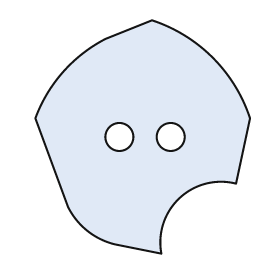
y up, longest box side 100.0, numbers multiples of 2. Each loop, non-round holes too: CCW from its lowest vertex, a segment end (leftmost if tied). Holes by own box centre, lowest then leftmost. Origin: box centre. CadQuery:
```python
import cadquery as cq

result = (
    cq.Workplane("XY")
    .moveTo(8.0, -50.0)
    .threePointArc((16.0, -26.0), (40.0, -20.0))
    .lineTo(46.0, 8.0)
    .threePointArc((30.0, 34.0), (4.0, 50.0))
    .lineTo(-16.0, 42.0)
    .threePointArc((-34.0, 28.0), (-46.0, 8.0))
    .lineTo(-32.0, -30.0)
    .threePointArc((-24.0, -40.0), (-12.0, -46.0))
    .close()
    .moveTo(-10.0, 0.0)
    .circle(6.0)
    .moveTo(12.0, 0.0)
    .circle(6.0)
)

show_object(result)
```